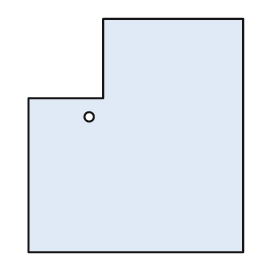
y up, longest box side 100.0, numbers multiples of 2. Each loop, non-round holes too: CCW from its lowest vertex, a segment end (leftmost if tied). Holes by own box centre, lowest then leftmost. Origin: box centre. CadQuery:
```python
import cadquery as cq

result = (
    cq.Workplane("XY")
    .moveTo(-46.0, -50.0)
    .lineTo(46.0, -50.0)
    .lineTo(46.0, 50.0)
    .lineTo(-14.0, 50.0)
    .lineTo(-14.0, 16.0)
    .lineTo(-46.0, 16.0)
    .close()
    .moveTo(-20.0, 8.0)
    .circle(2.0)
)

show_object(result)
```